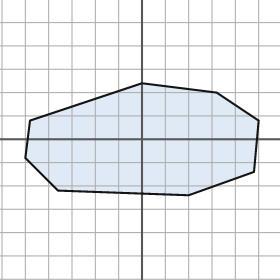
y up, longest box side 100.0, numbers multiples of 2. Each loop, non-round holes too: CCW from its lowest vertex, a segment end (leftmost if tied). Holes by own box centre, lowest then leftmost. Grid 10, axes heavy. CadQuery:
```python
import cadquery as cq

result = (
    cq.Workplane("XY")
    .moveTo(20.0, -24.0)
    .lineTo(48.0, -14.0)
    .lineTo(50.0, 8.0)
    .lineTo(32.0, 20.0)
    .lineTo(0.0, 24.0)
    .lineTo(-48.0, 8.0)
    .lineTo(-50.0, -8.0)
    .lineTo(-36.0, -22.0)
    .close()
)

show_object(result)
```